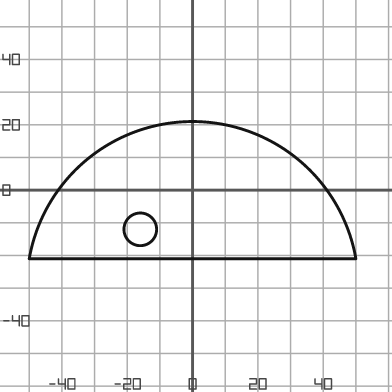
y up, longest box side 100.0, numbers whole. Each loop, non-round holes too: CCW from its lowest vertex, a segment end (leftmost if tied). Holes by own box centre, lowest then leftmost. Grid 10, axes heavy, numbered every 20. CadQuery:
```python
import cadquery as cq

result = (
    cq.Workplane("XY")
    .moveTo(-50.0, -21.0)
    .lineTo(50.0, -21.0)
    .threePointArc((0.0, 21.0), (-50.0, -21.0))
    .close()
    .moveTo(-16.0, -12.0)
    .circle(5.0)
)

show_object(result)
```